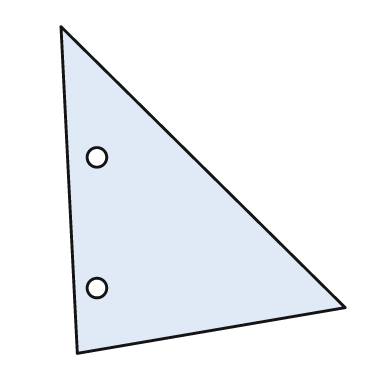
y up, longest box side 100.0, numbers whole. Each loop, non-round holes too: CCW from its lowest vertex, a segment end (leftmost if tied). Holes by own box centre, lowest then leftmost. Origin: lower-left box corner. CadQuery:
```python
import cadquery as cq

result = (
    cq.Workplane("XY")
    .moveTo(5.0, 0.0)
    .lineTo(87.0, 14.0)
    .lineTo(0.0, 100.0)
    .close()
    .moveTo(11.0, 20.0)
    .circle(3.0)
    .moveTo(11.0, 60.0)
    .circle(3.0)
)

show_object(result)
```